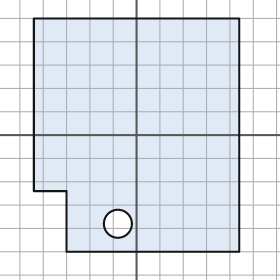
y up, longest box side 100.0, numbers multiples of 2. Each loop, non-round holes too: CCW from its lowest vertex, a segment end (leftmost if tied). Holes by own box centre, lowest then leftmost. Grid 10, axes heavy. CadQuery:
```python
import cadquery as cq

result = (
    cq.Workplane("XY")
    .moveTo(-30.0, -50.0)
    .lineTo(44.0, -50.0)
    .lineTo(44.0, 50.0)
    .lineTo(-44.0, 50.0)
    .lineTo(-44.0, -24.0)
    .lineTo(-30.0, -24.0)
    .close()
    .moveTo(-8.0, -38.0)
    .circle(6.0)
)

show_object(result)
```